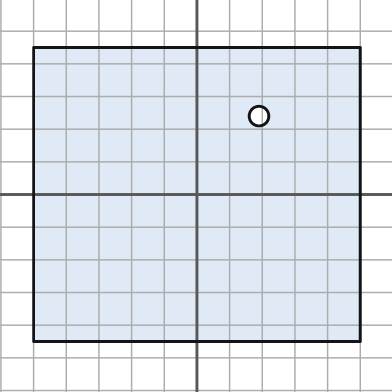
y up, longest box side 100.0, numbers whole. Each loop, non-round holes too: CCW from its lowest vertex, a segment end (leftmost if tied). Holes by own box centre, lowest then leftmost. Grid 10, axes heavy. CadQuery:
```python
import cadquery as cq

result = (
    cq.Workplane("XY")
    .moveTo(-50.0, -45.0)
    .lineTo(50.0, -45.0)
    .lineTo(50.0, 45.0)
    .lineTo(-50.0, 45.0)
    .close()
    .moveTo(19.0, 24.0)
    .circle(3.0)
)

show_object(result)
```